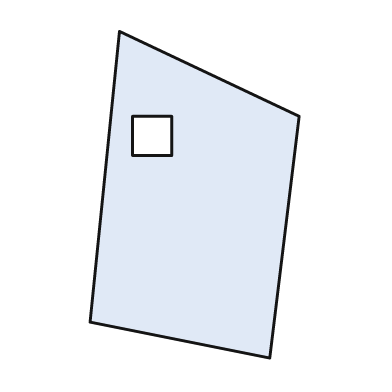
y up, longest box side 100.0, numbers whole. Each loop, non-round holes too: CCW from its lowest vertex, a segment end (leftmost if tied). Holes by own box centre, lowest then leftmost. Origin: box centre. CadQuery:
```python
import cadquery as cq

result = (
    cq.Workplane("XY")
    .moveTo(23.0, -50.0)
    .lineTo(32.0, 24.0)
    .lineTo(-23.0, 50.0)
    .lineTo(-32.0, -39.0)
    .close()
    .moveTo(-19.0, 12.0)
    .lineTo(-7.0, 12.0)
    .lineTo(-7.0, 24.0)
    .lineTo(-19.0, 24.0)
    .close()
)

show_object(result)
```